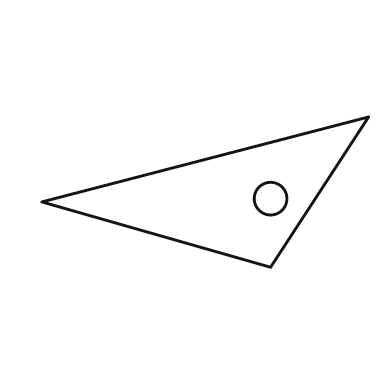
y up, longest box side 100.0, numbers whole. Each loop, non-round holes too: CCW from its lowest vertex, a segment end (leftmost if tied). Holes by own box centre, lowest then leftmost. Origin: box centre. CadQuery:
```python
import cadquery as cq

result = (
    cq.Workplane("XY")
    .moveTo(20.0, -23.0)
    .lineTo(50.0, 23.0)
    .lineTo(-50.0, -3.0)
    .close()
    .moveTo(20.0, -2.0)
    .circle(5.0)
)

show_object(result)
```